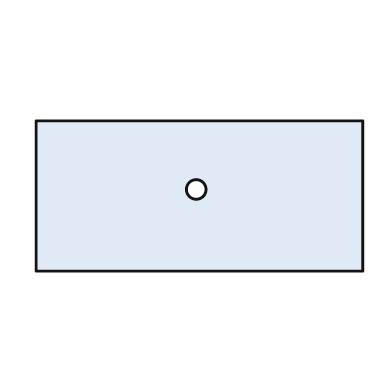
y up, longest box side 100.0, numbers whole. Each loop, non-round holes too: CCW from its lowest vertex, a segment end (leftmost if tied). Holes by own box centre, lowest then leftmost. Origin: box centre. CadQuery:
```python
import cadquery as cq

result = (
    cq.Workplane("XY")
    .moveTo(-50.0, -23.0)
    .lineTo(50.0, -23.0)
    .lineTo(50.0, 23.0)
    .lineTo(-50.0, 23.0)
    .close()
    .moveTo(-1.0, 2.0)
    .circle(3.0)
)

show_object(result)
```